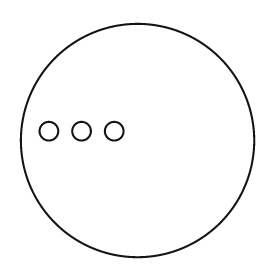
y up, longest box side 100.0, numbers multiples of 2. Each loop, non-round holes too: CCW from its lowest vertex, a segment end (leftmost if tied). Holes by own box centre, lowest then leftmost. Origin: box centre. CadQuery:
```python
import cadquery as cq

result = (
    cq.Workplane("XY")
    .moveTo(0.0, 0.0)
    .circle(50.0)
    .moveTo(-38.0, 4.0)
    .circle(4.0)
    .moveTo(-24.0, 4.0)
    .circle(4.0)
    .moveTo(-10.0, 4.0)
    .circle(4.0)
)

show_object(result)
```